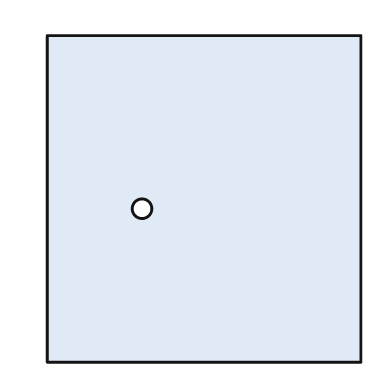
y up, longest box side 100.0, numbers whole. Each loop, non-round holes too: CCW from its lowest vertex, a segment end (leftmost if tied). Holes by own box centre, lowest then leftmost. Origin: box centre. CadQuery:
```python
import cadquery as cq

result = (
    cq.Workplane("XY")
    .moveTo(-48.0, -50.0)
    .lineTo(48.0, -50.0)
    .lineTo(48.0, 50.0)
    .lineTo(-48.0, 50.0)
    .close()
    .moveTo(-19.0, -3.0)
    .circle(3.0)
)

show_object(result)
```